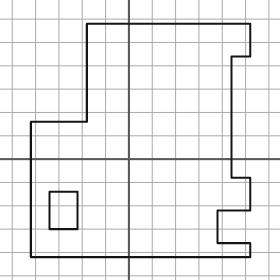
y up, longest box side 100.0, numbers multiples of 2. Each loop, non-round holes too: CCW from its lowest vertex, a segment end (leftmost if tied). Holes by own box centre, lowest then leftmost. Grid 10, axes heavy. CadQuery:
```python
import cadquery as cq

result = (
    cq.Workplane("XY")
    .moveTo(-42.0, -42.0)
    .lineTo(52.0, -42.0)
    .lineTo(52.0, -36.0)
    .lineTo(38.0, -36.0)
    .lineTo(38.0, -22.0)
    .lineTo(52.0, -22.0)
    .lineTo(52.0, -8.0)
    .lineTo(44.0, -8.0)
    .lineTo(44.0, 44.0)
    .lineTo(52.0, 44.0)
    .lineTo(52.0, 58.0)
    .lineTo(-18.0, 58.0)
    .lineTo(-18.0, 16.0)
    .lineTo(-42.0, 16.0)
    .close()
    .moveTo(-34.0, -30.0)
    .lineTo(-22.0, -30.0)
    .lineTo(-22.0, -14.0)
    .lineTo(-34.0, -14.0)
    .close()
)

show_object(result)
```